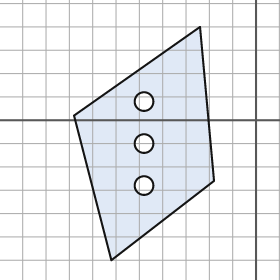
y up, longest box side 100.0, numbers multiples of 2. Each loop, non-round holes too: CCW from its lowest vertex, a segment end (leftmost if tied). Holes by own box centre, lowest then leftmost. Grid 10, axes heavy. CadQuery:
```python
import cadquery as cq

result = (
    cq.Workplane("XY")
    .moveTo(-62.0, -60.0)
    .lineTo(-18.0, -26.0)
    .lineTo(-24.0, 40.0)
    .lineTo(-78.0, 2.0)
    .close()
    .moveTo(-48.0, -28.0)
    .circle(4.0)
    .moveTo(-48.0, -10.0)
    .circle(4.0)
    .moveTo(-48.0, 8.0)
    .circle(4.0)
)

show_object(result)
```